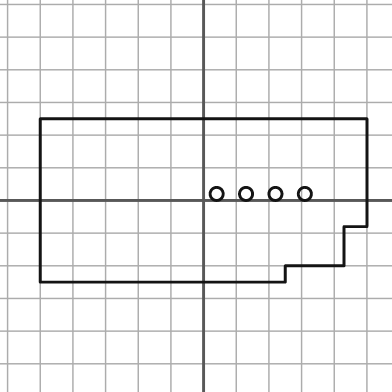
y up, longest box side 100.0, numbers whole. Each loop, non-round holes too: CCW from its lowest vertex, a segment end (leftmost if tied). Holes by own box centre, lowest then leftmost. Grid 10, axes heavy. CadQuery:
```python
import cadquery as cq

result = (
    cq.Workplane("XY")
    .moveTo(-50.0, -25.0)
    .lineTo(25.0, -25.0)
    .lineTo(25.0, -20.0)
    .lineTo(43.0, -20.0)
    .lineTo(43.0, -8.0)
    .lineTo(50.0, -8.0)
    .lineTo(50.0, 25.0)
    .lineTo(-50.0, 25.0)
    .close()
    .moveTo(4.0, 2.0)
    .circle(2.0)
    .moveTo(13.0, 2.0)
    .circle(2.0)
    .moveTo(22.0, 2.0)
    .circle(2.0)
    .moveTo(31.0, 2.0)
    .circle(2.0)
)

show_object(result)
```